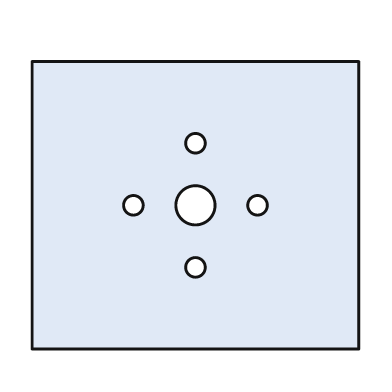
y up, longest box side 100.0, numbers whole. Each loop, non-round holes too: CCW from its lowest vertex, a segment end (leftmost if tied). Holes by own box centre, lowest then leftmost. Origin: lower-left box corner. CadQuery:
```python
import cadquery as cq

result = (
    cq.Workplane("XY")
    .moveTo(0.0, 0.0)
    .lineTo(100.0, 0.0)
    .lineTo(100.0, 88.0)
    .lineTo(0.0, 88.0)
    .close()
    .moveTo(50.0, 25.0)
    .circle(3.0)
    .moveTo(31.0, 44.0)
    .circle(3.0)
    .moveTo(50.0, 44.0)
    .circle(6.0)
    .moveTo(69.0, 44.0)
    .circle(3.0)
    .moveTo(50.0, 63.0)
    .circle(3.0)
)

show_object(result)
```